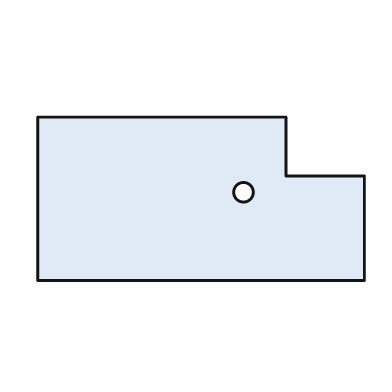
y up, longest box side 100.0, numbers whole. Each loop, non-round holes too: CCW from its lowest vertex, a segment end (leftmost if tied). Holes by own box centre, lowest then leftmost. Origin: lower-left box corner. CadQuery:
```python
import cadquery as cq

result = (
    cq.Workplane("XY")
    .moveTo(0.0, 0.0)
    .lineTo(100.0, 0.0)
    .lineTo(100.0, 32.0)
    .lineTo(76.0, 32.0)
    .lineTo(76.0, 50.0)
    .lineTo(0.0, 50.0)
    .close()
    .moveTo(63.0, 27.0)
    .circle(3.0)
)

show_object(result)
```